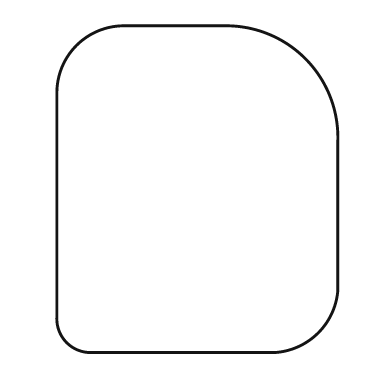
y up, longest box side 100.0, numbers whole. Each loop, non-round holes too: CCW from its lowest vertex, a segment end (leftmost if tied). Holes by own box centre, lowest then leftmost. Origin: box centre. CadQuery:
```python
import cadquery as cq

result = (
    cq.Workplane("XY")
    .moveTo(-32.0, -50.0)
    .lineTo(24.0, -50.0)
    .threePointArc((37.0, -44.0), (43.0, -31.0))
    .lineTo(43.0, 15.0)
    .threePointArc((33.0, 40.0), (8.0, 50.0))
    .lineTo(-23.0, 50.0)
    .threePointArc((-37.0, 44.0), (-43.0, 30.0))
    .lineTo(-43.0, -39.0)
    .threePointArc((-40.0, -47.0), (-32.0, -50.0))
    .close()
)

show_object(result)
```